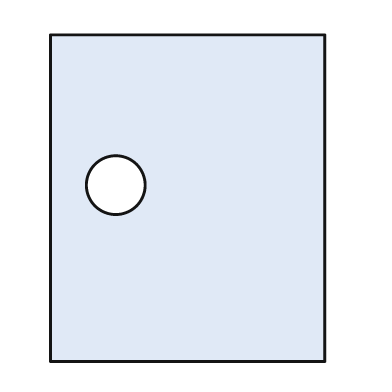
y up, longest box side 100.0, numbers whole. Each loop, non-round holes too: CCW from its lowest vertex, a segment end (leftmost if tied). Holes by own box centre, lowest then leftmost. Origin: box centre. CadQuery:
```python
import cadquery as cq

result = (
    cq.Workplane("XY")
    .moveTo(-42.0, -50.0)
    .lineTo(42.0, -50.0)
    .lineTo(42.0, 50.0)
    .lineTo(-42.0, 50.0)
    .close()
    .moveTo(-22.0, 4.0)
    .circle(9.0)
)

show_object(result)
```